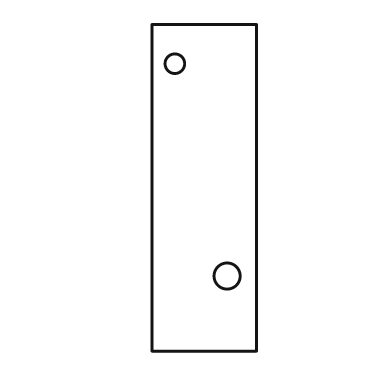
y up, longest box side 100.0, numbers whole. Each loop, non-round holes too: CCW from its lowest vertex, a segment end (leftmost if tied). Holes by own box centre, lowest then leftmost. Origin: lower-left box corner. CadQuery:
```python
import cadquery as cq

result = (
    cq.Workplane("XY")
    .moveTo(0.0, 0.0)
    .lineTo(32.0, 0.0)
    .lineTo(32.0, 100.0)
    .lineTo(0.0, 100.0)
    .close()
    .moveTo(23.0, 23.0)
    .circle(4.0)
    .moveTo(7.0, 88.0)
    .circle(3.0)
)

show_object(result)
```